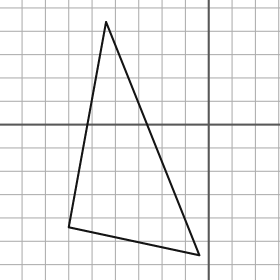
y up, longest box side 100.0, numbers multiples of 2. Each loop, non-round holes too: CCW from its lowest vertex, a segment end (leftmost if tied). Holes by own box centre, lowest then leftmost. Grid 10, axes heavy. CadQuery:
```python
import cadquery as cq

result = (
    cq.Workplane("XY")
    .moveTo(-4.0, -56.0)
    .lineTo(-44.0, 44.0)
    .lineTo(-60.0, -44.0)
    .close()
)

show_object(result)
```